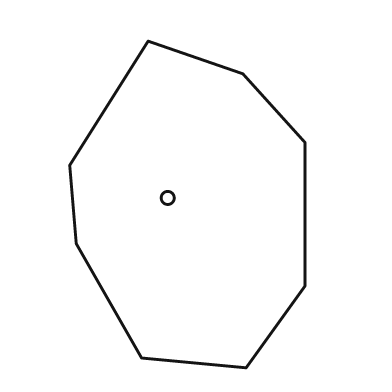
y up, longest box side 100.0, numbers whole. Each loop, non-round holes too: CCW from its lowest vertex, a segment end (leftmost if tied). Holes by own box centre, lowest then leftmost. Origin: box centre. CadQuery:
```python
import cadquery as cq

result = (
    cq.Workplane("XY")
    .moveTo(18.0, -50.0)
    .lineTo(36.0, -25.0)
    .lineTo(36.0, 19.0)
    .lineTo(17.0, 40.0)
    .lineTo(-12.0, 50.0)
    .lineTo(-36.0, 12.0)
    .lineTo(-34.0, -12.0)
    .lineTo(-14.0, -47.0)
    .close()
    .moveTo(-6.0, 2.0)
    .circle(2.0)
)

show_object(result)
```